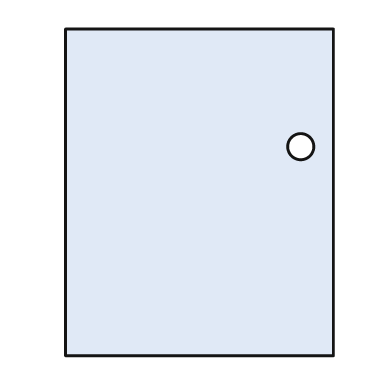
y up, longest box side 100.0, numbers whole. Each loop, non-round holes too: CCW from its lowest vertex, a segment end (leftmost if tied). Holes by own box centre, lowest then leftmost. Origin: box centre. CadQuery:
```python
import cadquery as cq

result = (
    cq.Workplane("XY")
    .moveTo(-41.0, -50.0)
    .lineTo(41.0, -50.0)
    .lineTo(41.0, 50.0)
    .lineTo(-41.0, 50.0)
    .close()
    .moveTo(31.0, 14.0)
    .circle(4.0)
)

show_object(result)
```